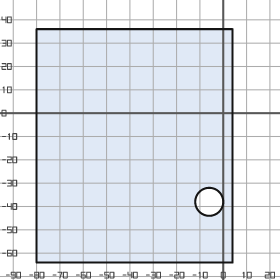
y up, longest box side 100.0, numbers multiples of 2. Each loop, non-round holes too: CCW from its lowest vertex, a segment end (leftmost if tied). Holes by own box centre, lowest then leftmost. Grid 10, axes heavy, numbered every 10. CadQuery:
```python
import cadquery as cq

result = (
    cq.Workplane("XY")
    .moveTo(-80.0, -64.0)
    .lineTo(4.0, -64.0)
    .lineTo(4.0, 36.0)
    .lineTo(-80.0, 36.0)
    .close()
    .moveTo(-6.0, -38.0)
    .circle(6.0)
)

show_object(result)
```